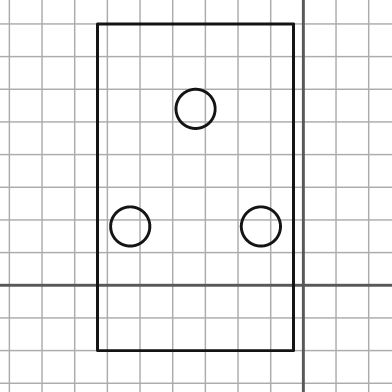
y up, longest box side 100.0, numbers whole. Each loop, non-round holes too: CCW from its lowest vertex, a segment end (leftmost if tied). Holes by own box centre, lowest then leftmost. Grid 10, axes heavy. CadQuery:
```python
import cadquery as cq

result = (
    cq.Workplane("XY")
    .moveTo(-63.0, -20.0)
    .lineTo(-3.0, -20.0)
    .lineTo(-3.0, 80.0)
    .lineTo(-63.0, 80.0)
    .close()
    .moveTo(-53.0, 18.0)
    .circle(6.0)
    .moveTo(-13.0, 18.0)
    .circle(6.0)
    .moveTo(-33.0, 54.0)
    .circle(6.0)
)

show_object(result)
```